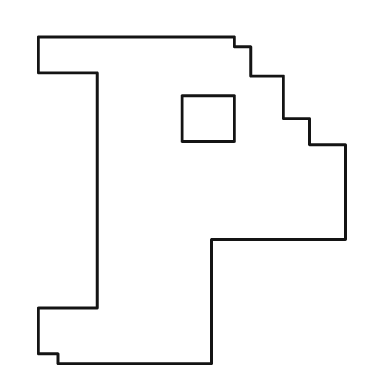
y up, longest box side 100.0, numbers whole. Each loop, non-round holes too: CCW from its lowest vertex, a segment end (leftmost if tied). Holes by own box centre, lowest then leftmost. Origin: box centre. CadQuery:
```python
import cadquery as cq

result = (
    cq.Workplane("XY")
    .moveTo(-41.0, -50.0)
    .lineTo(6.0, -50.0)
    .lineTo(6.0, -12.0)
    .lineTo(47.0, -12.0)
    .lineTo(47.0, 17.0)
    .lineTo(36.0, 17.0)
    .lineTo(36.0, 25.0)
    .lineTo(28.0, 25.0)
    .lineTo(28.0, 38.0)
    .lineTo(18.0, 38.0)
    .lineTo(18.0, 47.0)
    .lineTo(13.0, 47.0)
    .lineTo(13.0, 50.0)
    .lineTo(-47.0, 50.0)
    .lineTo(-47.0, 39.0)
    .lineTo(-29.0, 39.0)
    .lineTo(-29.0, -33.0)
    .lineTo(-47.0, -33.0)
    .lineTo(-47.0, -47.0)
    .lineTo(-41.0, -47.0)
    .close()
    .moveTo(-3.0, 18.0)
    .lineTo(13.0, 18.0)
    .lineTo(13.0, 32.0)
    .lineTo(-3.0, 32.0)
    .close()
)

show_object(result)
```